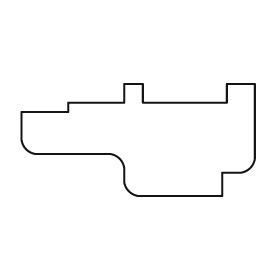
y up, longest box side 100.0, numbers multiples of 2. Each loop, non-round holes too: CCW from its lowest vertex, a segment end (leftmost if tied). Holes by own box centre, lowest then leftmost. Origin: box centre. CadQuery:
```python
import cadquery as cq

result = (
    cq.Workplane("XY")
    .moveTo(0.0, -24.0)
    .lineTo(36.0, -24.0)
    .lineTo(36.0, -14.0)
    .lineTo(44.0, -14.0)
    .threePointArc((48.0, -12.0), (50.0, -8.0))
    .lineTo(50.0, 24.0)
    .lineTo(38.0, 24.0)
    .lineTo(38.0, 16.0)
    .lineTo(2.0, 16.0)
    .lineTo(2.0, 24.0)
    .lineTo(-6.0, 24.0)
    .lineTo(-6.0, 16.0)
    .lineTo(-30.0, 16.0)
    .lineTo(-30.0, 12.0)
    .lineTo(-50.0, 12.0)
    .lineTo(-50.0, 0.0)
    .threePointArc((-48.0, -4.0), (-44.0, -6.0))
    .lineTo(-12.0, -6.0)
    .threePointArc((-8.0, -8.0), (-6.0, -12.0))
    .lineTo(-6.0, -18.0)
    .threePointArc((-4.0, -22.0), (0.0, -24.0))
    .close()
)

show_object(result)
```